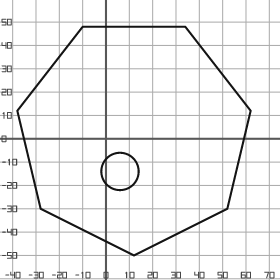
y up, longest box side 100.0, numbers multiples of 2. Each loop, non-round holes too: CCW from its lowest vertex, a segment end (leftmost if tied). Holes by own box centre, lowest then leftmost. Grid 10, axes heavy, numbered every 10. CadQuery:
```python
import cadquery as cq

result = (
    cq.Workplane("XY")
    .moveTo(12.0, -50.0)
    .lineTo(52.0, -30.0)
    .lineTo(62.0, 12.0)
    .lineTo(34.0, 48.0)
    .lineTo(-10.0, 48.0)
    .lineTo(-38.0, 12.0)
    .lineTo(-28.0, -30.0)
    .close()
    .moveTo(6.0, -14.0)
    .circle(8.0)
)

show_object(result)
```